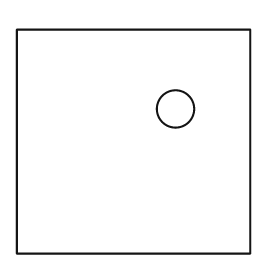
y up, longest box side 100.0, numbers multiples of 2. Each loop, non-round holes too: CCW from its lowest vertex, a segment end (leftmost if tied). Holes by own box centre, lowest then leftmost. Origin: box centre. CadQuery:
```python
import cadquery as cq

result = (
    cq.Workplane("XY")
    .moveTo(-50.0, -48.0)
    .lineTo(50.0, -48.0)
    .lineTo(50.0, 48.0)
    .lineTo(-50.0, 48.0)
    .close()
    .moveTo(18.0, 14.0)
    .circle(8.0)
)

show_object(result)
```